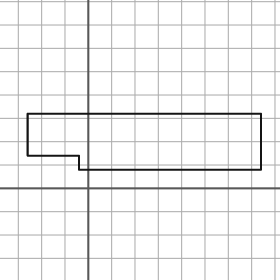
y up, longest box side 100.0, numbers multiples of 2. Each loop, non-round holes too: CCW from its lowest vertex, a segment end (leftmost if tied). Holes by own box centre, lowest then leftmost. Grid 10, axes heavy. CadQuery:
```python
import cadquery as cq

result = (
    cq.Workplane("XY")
    .moveTo(-4.0, 8.0)
    .lineTo(74.0, 8.0)
    .lineTo(74.0, 32.0)
    .lineTo(-26.0, 32.0)
    .lineTo(-26.0, 14.0)
    .lineTo(-4.0, 14.0)
    .close()
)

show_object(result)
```